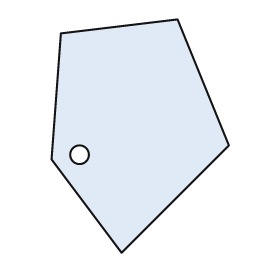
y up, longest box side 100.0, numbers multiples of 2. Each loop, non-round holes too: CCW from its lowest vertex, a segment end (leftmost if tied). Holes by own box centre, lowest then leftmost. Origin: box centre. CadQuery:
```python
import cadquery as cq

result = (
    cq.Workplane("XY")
    .moveTo(-8.0, -50.0)
    .lineTo(38.0, -4.0)
    .lineTo(16.0, 50.0)
    .lineTo(-34.0, 44.0)
    .lineTo(-38.0, -10.0)
    .close()
    .moveTo(-26.0, -8.0)
    .circle(4.0)
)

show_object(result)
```